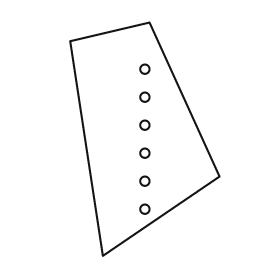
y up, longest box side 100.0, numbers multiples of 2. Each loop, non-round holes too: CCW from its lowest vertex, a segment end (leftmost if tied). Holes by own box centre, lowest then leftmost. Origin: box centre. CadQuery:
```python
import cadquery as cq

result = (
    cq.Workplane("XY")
    .moveTo(-18.0, -50.0)
    .lineTo(32.0, -16.0)
    .lineTo(2.0, 50.0)
    .lineTo(-32.0, 42.0)
    .close()
    .moveTo(0.0, -30.0)
    .circle(2.0)
    .moveTo(0.0, -18.0)
    .circle(2.0)
    .moveTo(0.0, -6.0)
    .circle(2.0)
    .moveTo(0.0, 6.0)
    .circle(2.0)
    .moveTo(0.0, 18.0)
    .circle(2.0)
    .moveTo(0.0, 30.0)
    .circle(2.0)
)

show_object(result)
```